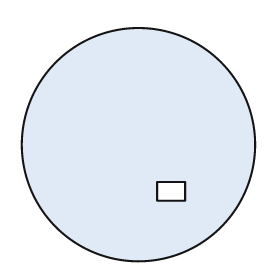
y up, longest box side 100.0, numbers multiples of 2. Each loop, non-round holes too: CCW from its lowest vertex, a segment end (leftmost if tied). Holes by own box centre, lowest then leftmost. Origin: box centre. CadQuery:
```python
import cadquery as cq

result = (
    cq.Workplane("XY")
    .moveTo(0.0, 0.0)
    .circle(50.0)
    .moveTo(8.0, -24.0)
    .lineTo(20.0, -24.0)
    .lineTo(20.0, -16.0)
    .lineTo(8.0, -16.0)
    .close()
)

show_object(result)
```